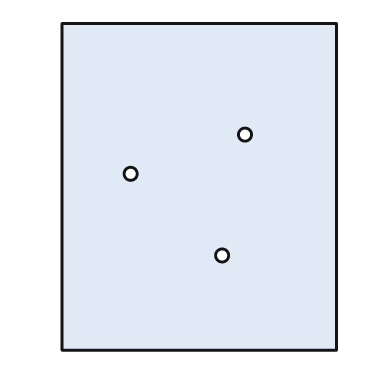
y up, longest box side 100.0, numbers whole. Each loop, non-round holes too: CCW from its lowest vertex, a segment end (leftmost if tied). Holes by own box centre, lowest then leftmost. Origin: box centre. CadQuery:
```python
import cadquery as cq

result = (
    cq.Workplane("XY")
    .moveTo(-42.0, -50.0)
    .lineTo(42.0, -50.0)
    .lineTo(42.0, 50.0)
    .lineTo(-42.0, 50.0)
    .close()
    .moveTo(7.0, -21.0)
    .circle(2.0)
    .moveTo(-21.0, 4.0)
    .circle(2.0)
    .moveTo(14.0, 16.0)
    .circle(2.0)
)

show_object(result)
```